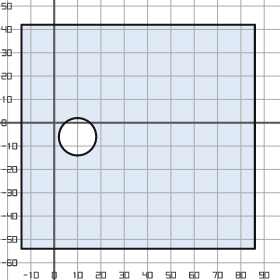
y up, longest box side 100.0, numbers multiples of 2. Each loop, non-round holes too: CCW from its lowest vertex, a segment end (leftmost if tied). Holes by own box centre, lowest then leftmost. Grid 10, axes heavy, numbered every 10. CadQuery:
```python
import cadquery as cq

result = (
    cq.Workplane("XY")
    .moveTo(-14.0, -54.0)
    .lineTo(86.0, -54.0)
    .lineTo(86.0, 42.0)
    .lineTo(-14.0, 42.0)
    .close()
    .moveTo(10.0, -6.0)
    .circle(8.0)
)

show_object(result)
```